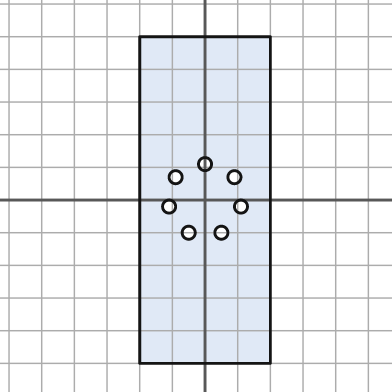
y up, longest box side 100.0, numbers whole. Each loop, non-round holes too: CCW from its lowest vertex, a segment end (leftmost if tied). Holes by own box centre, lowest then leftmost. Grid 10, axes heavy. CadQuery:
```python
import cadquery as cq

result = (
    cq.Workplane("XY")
    .moveTo(-20.0, -50.0)
    .lineTo(20.0, -50.0)
    .lineTo(20.0, 50.0)
    .lineTo(-20.0, 50.0)
    .close()
    .moveTo(-5.0, -10.0)
    .circle(2.0)
    .moveTo(5.0, -10.0)
    .circle(2.0)
    .moveTo(-11.0, -2.0)
    .circle(2.0)
    .moveTo(11.0, -2.0)
    .circle(2.0)
    .moveTo(-9.0, 7.0)
    .circle(2.0)
    .moveTo(9.0, 7.0)
    .circle(2.0)
    .moveTo(0.0, 11.0)
    .circle(2.0)
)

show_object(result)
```